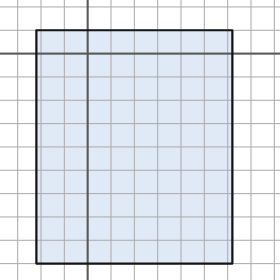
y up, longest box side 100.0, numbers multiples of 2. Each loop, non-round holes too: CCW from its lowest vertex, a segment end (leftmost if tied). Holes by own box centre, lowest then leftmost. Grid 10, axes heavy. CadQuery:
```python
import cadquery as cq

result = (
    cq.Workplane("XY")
    .moveTo(-22.0, -90.0)
    .lineTo(62.0, -90.0)
    .lineTo(62.0, 10.0)
    .lineTo(-22.0, 10.0)
    .close()
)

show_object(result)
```